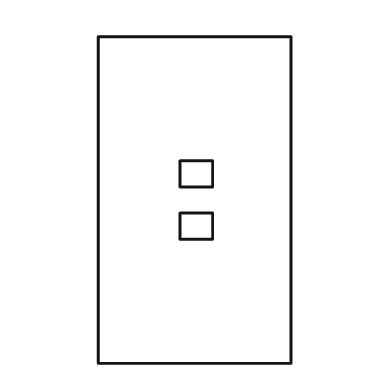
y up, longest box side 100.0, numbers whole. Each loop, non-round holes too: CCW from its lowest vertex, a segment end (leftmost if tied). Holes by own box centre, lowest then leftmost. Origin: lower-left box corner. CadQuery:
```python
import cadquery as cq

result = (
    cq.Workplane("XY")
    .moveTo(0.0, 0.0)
    .lineTo(59.0, 0.0)
    .lineTo(59.0, 100.0)
    .lineTo(0.0, 100.0)
    .close()
    .moveTo(25.0, 38.0)
    .lineTo(35.0, 38.0)
    .lineTo(35.0, 46.0)
    .lineTo(25.0, 46.0)
    .close()
    .moveTo(25.0, 54.0)
    .lineTo(35.0, 54.0)
    .lineTo(35.0, 62.0)
    .lineTo(25.0, 62.0)
    .close()
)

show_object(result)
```